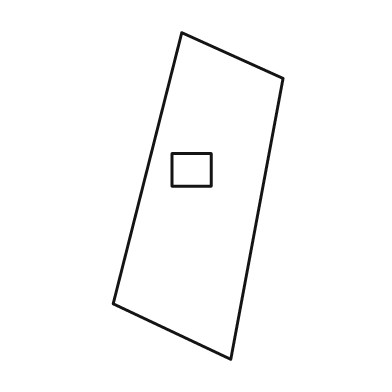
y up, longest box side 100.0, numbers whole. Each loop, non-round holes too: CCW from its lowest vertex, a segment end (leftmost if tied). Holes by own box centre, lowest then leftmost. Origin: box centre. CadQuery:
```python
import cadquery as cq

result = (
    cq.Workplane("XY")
    .moveTo(10.0, -50.0)
    .lineTo(26.0, 36.0)
    .lineTo(-5.0, 50.0)
    .lineTo(-26.0, -33.0)
    .close()
    .moveTo(-8.0, 3.0)
    .lineTo(4.0, 3.0)
    .lineTo(4.0, 13.0)
    .lineTo(-8.0, 13.0)
    .close()
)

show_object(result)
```